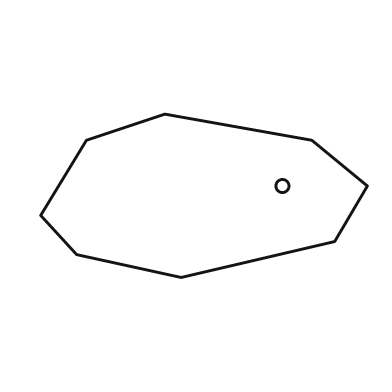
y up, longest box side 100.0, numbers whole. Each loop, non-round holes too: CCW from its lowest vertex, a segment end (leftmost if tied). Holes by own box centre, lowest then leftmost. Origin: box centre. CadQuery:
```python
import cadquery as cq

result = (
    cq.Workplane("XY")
    .moveTo(-7.0, -25.0)
    .lineTo(40.0, -14.0)
    .lineTo(50.0, 3.0)
    .lineTo(33.0, 17.0)
    .lineTo(-12.0, 25.0)
    .lineTo(-36.0, 17.0)
    .lineTo(-50.0, -6.0)
    .lineTo(-39.0, -18.0)
    .close()
    .moveTo(24.0, 3.0)
    .circle(2.0)
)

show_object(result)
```